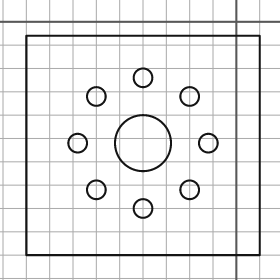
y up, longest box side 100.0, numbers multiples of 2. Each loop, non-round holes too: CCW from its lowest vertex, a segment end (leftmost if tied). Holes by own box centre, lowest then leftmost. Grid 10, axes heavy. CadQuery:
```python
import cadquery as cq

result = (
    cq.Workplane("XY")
    .moveTo(-90.0, -100.0)
    .lineTo(10.0, -100.0)
    .lineTo(10.0, -6.0)
    .lineTo(-90.0, -6.0)
    .close()
    .moveTo(-40.0, -80.0)
    .circle(4.0)
    .moveTo(-60.0, -72.0)
    .circle(4.0)
    .moveTo(-20.0, -72.0)
    .circle(4.0)
    .moveTo(-68.0, -52.0)
    .circle(4.0)
    .moveTo(-40.0, -52.0)
    .circle(12.0)
    .moveTo(-12.0, -52.0)
    .circle(4.0)
    .moveTo(-60.0, -32.0)
    .circle(4.0)
    .moveTo(-20.0, -32.0)
    .circle(4.0)
    .moveTo(-40.0, -24.0)
    .circle(4.0)
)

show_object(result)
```